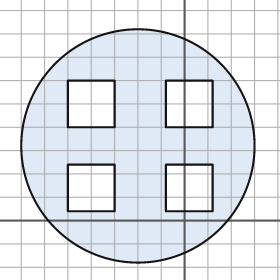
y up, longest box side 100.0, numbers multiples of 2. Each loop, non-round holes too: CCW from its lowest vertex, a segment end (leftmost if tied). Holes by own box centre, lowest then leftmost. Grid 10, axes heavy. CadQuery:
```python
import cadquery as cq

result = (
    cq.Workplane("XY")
    .moveTo(-20.0, 32.0)
    .circle(50.0)
    .moveTo(-50.0, 4.0)
    .lineTo(-30.0, 4.0)
    .lineTo(-30.0, 24.0)
    .lineTo(-50.0, 24.0)
    .close()
    .moveTo(-8.0, 4.0)
    .lineTo(12.0, 4.0)
    .lineTo(12.0, 24.0)
    .lineTo(-8.0, 24.0)
    .close()
    .moveTo(-50.0, 40.0)
    .lineTo(-30.0, 40.0)
    .lineTo(-30.0, 60.0)
    .lineTo(-50.0, 60.0)
    .close()
    .moveTo(-8.0, 40.0)
    .lineTo(12.0, 40.0)
    .lineTo(12.0, 60.0)
    .lineTo(-8.0, 60.0)
    .close()
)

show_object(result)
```